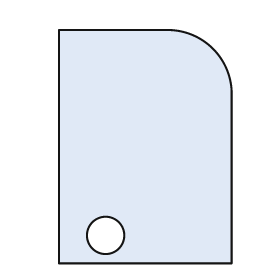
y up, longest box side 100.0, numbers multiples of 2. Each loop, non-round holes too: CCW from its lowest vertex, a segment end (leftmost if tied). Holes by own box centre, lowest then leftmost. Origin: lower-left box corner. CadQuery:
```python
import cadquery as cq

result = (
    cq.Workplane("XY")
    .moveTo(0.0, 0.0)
    .lineTo(74.0, 0.0)
    .lineTo(74.0, 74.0)
    .threePointArc((66.0, 92.0), (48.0, 100.0))
    .lineTo(0.0, 100.0)
    .close()
    .moveTo(20.0, 12.0)
    .circle(8.0)
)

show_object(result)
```